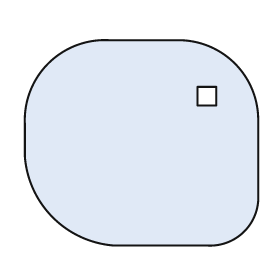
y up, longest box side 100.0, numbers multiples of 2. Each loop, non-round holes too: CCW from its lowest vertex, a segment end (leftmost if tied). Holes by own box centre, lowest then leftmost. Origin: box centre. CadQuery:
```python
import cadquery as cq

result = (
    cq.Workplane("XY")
    .moveTo(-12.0, -44.0)
    .lineTo(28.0, -44.0)
    .threePointArc((44.0, -38.0), (50.0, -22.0))
    .lineTo(50.0, 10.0)
    .threePointArc((40.0, 34.0), (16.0, 44.0))
    .lineTo(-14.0, 44.0)
    .threePointArc((-40.0, 34.0), (-50.0, 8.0))
    .lineTo(-50.0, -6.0)
    .threePointArc((-38.0, -32.0), (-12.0, -44.0))
    .close()
    .moveTo(24.0, 16.0)
    .lineTo(32.0, 16.0)
    .lineTo(32.0, 24.0)
    .lineTo(24.0, 24.0)
    .close()
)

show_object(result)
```